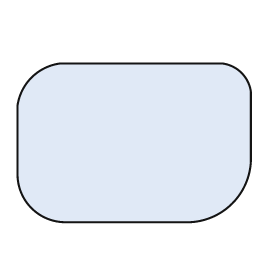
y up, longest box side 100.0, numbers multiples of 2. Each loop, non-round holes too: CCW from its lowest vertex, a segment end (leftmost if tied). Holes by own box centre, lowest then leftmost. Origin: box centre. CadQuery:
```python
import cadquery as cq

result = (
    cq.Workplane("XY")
    .moveTo(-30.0, -34.0)
    .lineTo(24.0, -34.0)
    .threePointArc((42.0, -26.0), (50.0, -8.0))
    .lineTo(50.0, 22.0)
    .threePointArc((46.0, 30.0), (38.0, 34.0))
    .lineTo(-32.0, 34.0)
    .threePointArc((-44.0, 28.0), (-50.0, 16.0))
    .lineTo(-50.0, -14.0)
    .threePointArc((-44.0, -28.0), (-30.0, -34.0))
    .close()
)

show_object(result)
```